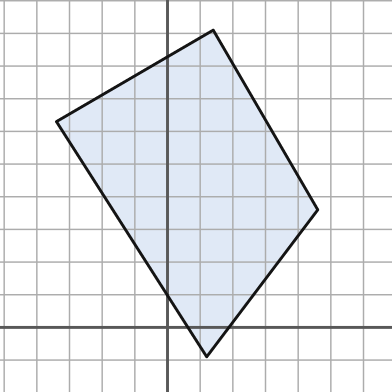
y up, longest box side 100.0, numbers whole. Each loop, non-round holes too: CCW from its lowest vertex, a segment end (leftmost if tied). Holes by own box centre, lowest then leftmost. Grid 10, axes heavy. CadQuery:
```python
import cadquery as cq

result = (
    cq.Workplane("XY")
    .moveTo(12.0, -9.0)
    .lineTo(46.0, 36.0)
    .lineTo(14.0, 91.0)
    .lineTo(-34.0, 63.0)
    .close()
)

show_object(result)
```